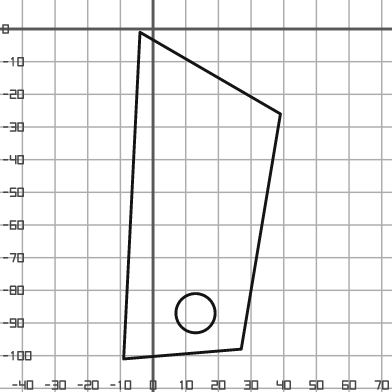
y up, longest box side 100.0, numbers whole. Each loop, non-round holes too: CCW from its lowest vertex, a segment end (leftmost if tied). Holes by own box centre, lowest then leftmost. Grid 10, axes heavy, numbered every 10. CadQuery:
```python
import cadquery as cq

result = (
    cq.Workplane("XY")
    .moveTo(-9.0, -101.0)
    .lineTo(27.0, -98.0)
    .lineTo(39.0, -26.0)
    .lineTo(-4.0, -1.0)
    .close()
    .moveTo(13.0, -87.0)
    .circle(6.0)
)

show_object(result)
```